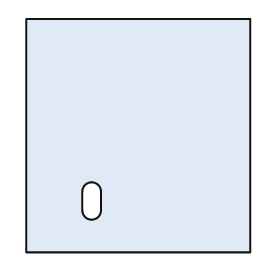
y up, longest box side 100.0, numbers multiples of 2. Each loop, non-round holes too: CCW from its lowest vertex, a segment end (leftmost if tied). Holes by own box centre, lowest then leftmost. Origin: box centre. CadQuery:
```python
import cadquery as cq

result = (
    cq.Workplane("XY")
    .moveTo(-48.0, -50.0)
    .lineTo(48.0, -50.0)
    .lineTo(48.0, 50.0)
    .lineTo(-48.0, 50.0)
    .close()
    .moveTo(-24.0, -32.0)
    .threePointArc((-20.0, -36.0), (-16.0, -32.0))
    .lineTo(-16.0, -24.0)
    .threePointArc((-20.0, -20.0), (-24.0, -24.0))
    .close()
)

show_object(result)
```